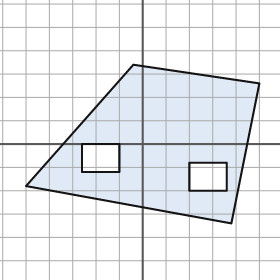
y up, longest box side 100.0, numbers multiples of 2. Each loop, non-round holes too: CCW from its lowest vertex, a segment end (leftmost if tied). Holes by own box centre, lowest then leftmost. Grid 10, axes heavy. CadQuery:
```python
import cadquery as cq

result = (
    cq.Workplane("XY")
    .moveTo(38.0, -34.0)
    .lineTo(50.0, 26.0)
    .lineTo(-4.0, 34.0)
    .lineTo(-50.0, -18.0)
    .close()
    .moveTo(20.0, -20.0)
    .lineTo(36.0, -20.0)
    .lineTo(36.0, -8.0)
    .lineTo(20.0, -8.0)
    .close()
    .moveTo(-26.0, -12.0)
    .lineTo(-10.0, -12.0)
    .lineTo(-10.0, 0.0)
    .lineTo(-26.0, 0.0)
    .close()
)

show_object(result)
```